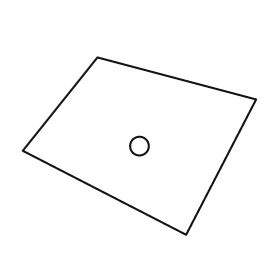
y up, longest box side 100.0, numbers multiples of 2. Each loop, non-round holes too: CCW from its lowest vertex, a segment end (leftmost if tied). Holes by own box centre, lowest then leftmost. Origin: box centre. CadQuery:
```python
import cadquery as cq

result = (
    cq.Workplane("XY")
    .moveTo(20.0, -38.0)
    .lineTo(50.0, 20.0)
    .lineTo(-18.0, 38.0)
    .lineTo(-50.0, -2.0)
    .close()
    .moveTo(0.0, 0.0)
    .circle(4.0)
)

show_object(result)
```